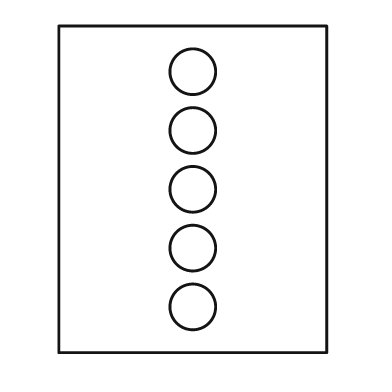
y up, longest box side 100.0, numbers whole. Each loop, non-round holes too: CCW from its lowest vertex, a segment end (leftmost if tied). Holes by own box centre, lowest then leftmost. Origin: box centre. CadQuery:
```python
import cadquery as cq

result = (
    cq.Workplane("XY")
    .moveTo(-41.0, -50.0)
    .lineTo(41.0, -50.0)
    .lineTo(41.0, 50.0)
    .lineTo(-41.0, 50.0)
    .close()
    .moveTo(0.0, -36.0)
    .circle(7.0)
    .moveTo(0.0, -18.0)
    .circle(7.0)
    .moveTo(0.0, 0.0)
    .circle(7.0)
    .moveTo(0.0, 18.0)
    .circle(7.0)
    .moveTo(0.0, 36.0)
    .circle(7.0)
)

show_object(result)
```